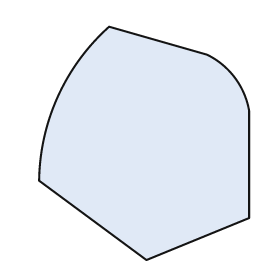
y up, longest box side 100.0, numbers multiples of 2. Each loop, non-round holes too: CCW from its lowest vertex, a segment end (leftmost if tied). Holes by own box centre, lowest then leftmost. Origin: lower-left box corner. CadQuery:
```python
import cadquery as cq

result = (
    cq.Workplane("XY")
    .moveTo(46.0, 0.0)
    .lineTo(90.0, 18.0)
    .lineTo(90.0, 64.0)
    .threePointArc((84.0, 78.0), (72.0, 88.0))
    .lineTo(30.0, 100.0)
    .threePointArc((8.0, 70.0), (0.0, 34.0))
    .close()
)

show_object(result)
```